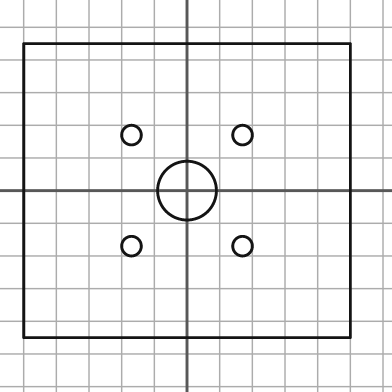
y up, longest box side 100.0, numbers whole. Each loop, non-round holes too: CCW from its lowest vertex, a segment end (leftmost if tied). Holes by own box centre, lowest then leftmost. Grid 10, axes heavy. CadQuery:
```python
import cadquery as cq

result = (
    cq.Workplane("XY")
    .moveTo(-50.0, -45.0)
    .lineTo(50.0, -45.0)
    .lineTo(50.0, 45.0)
    .lineTo(-50.0, 45.0)
    .close()
    .moveTo(-17.0, -17.0)
    .circle(3.0)
    .moveTo(17.0, -17.0)
    .circle(3.0)
    .moveTo(0.0, 0.0)
    .circle(9.0)
    .moveTo(-17.0, 17.0)
    .circle(3.0)
    .moveTo(17.0, 17.0)
    .circle(3.0)
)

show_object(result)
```